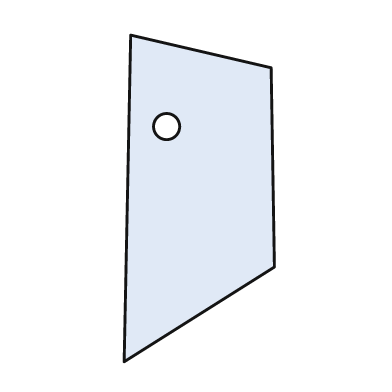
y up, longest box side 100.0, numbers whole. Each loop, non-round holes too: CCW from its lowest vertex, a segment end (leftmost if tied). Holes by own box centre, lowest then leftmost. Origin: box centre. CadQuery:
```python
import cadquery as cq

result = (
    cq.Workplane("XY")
    .moveTo(-23.0, -50.0)
    .lineTo(23.0, -21.0)
    .lineTo(22.0, 40.0)
    .lineTo(-21.0, 50.0)
    .close()
    .moveTo(-10.0, 22.0)
    .circle(4.0)
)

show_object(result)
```